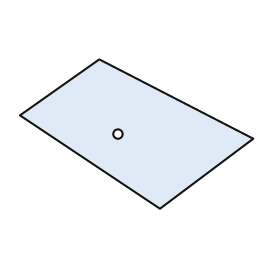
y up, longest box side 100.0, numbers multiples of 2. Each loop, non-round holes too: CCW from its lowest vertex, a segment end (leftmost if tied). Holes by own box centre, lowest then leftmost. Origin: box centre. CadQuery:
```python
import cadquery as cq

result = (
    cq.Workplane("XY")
    .moveTo(10.0, -32.0)
    .lineTo(50.0, -2.0)
    .lineTo(-16.0, 32.0)
    .lineTo(-50.0, 8.0)
    .close()
    .moveTo(-8.0, 0.0)
    .circle(2.0)
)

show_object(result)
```